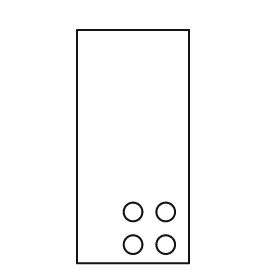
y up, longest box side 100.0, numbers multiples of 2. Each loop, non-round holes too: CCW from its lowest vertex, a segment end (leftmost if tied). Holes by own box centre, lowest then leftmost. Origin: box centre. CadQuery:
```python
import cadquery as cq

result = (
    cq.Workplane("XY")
    .moveTo(-24.0, -50.0)
    .lineTo(24.0, -50.0)
    .lineTo(24.0, 50.0)
    .lineTo(-24.0, 50.0)
    .close()
    .moveTo(0.0, -42.0)
    .circle(4.0)
    .moveTo(14.0, -42.0)
    .circle(4.0)
    .moveTo(0.0, -28.0)
    .circle(4.0)
    .moveTo(14.0, -28.0)
    .circle(4.0)
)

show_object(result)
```